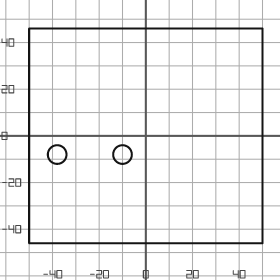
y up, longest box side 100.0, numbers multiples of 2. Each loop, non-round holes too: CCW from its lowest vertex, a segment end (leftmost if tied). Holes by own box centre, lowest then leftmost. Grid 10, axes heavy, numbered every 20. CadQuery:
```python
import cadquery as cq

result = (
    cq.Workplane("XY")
    .moveTo(-50.0, -46.0)
    .lineTo(50.0, -46.0)
    .lineTo(50.0, 46.0)
    .lineTo(-50.0, 46.0)
    .close()
    .moveTo(-38.0, -8.0)
    .circle(4.0)
    .moveTo(-10.0, -8.0)
    .circle(4.0)
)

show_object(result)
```